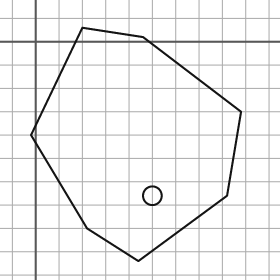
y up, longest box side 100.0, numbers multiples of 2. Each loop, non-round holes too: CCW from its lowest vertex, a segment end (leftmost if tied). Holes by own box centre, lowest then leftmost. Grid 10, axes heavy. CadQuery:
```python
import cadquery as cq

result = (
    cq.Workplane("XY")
    .moveTo(44.0, -94.0)
    .lineTo(82.0, -66.0)
    .lineTo(88.0, -30.0)
    .lineTo(46.0, 2.0)
    .lineTo(20.0, 6.0)
    .lineTo(-2.0, -40.0)
    .lineTo(22.0, -80.0)
    .close()
    .moveTo(50.0, -66.0)
    .circle(4.0)
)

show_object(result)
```